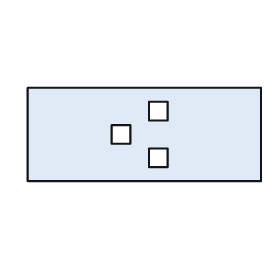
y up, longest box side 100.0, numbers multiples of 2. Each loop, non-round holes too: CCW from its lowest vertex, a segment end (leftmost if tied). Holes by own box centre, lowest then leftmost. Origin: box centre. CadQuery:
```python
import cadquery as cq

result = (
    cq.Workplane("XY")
    .moveTo(-50.0, -20.0)
    .lineTo(50.0, -20.0)
    .lineTo(50.0, 20.0)
    .lineTo(-50.0, 20.0)
    .close()
    .moveTo(2.0, -14.0)
    .lineTo(10.0, -14.0)
    .lineTo(10.0, -6.0)
    .lineTo(2.0, -6.0)
    .close()
    .moveTo(-14.0, -4.0)
    .lineTo(-6.0, -4.0)
    .lineTo(-6.0, 4.0)
    .lineTo(-14.0, 4.0)
    .close()
    .moveTo(2.0, 6.0)
    .lineTo(10.0, 6.0)
    .lineTo(10.0, 14.0)
    .lineTo(2.0, 14.0)
    .close()
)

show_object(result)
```